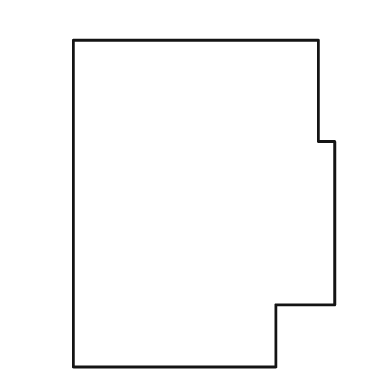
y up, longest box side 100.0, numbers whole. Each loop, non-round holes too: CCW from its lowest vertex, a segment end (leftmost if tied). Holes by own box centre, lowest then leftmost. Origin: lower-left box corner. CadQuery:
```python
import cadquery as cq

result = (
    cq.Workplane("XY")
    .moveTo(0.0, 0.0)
    .lineTo(62.0, 0.0)
    .lineTo(62.0, 19.0)
    .lineTo(80.0, 19.0)
    .lineTo(80.0, 69.0)
    .lineTo(75.0, 69.0)
    .lineTo(75.0, 100.0)
    .lineTo(0.0, 100.0)
    .close()
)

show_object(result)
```